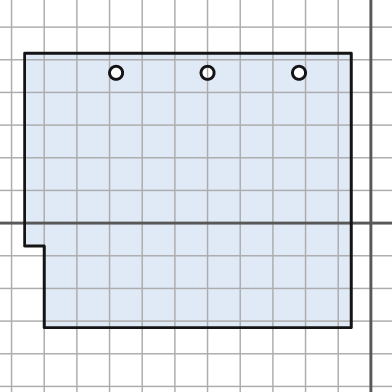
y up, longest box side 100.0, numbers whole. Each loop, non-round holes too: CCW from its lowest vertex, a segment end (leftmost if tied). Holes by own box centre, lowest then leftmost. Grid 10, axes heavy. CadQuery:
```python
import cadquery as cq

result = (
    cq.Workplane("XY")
    .moveTo(-100.0, -32.0)
    .lineTo(-6.0, -32.0)
    .lineTo(-6.0, 52.0)
    .lineTo(-106.0, 52.0)
    .lineTo(-106.0, -7.0)
    .lineTo(-100.0, -7.0)
    .close()
    .moveTo(-78.0, 46.0)
    .circle(2.0)
    .moveTo(-50.0, 46.0)
    .circle(2.0)
    .moveTo(-22.0, 46.0)
    .circle(2.0)
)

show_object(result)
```